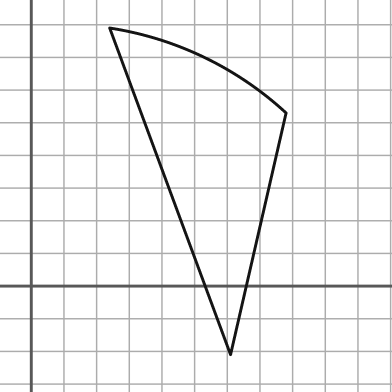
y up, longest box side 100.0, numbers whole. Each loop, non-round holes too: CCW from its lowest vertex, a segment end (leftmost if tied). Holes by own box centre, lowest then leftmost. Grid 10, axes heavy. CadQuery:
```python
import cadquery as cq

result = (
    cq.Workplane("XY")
    .moveTo(61.0, -21.0)
    .lineTo(78.0, 53.0)
    .threePointArc((53.0, 70.0), (24.0, 79.0))
    .close()
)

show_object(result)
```